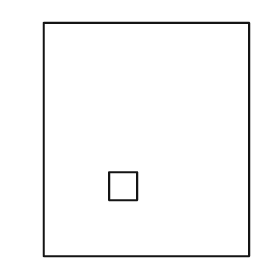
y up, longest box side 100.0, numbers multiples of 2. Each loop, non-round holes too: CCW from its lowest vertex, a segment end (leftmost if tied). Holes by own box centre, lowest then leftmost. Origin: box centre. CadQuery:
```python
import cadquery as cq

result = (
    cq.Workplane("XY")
    .moveTo(-44.0, -50.0)
    .lineTo(44.0, -50.0)
    .lineTo(44.0, 50.0)
    .lineTo(-44.0, 50.0)
    .close()
    .moveTo(-16.0, -26.0)
    .lineTo(-4.0, -26.0)
    .lineTo(-4.0, -14.0)
    .lineTo(-16.0, -14.0)
    .close()
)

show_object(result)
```